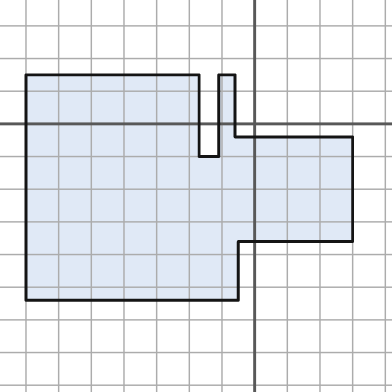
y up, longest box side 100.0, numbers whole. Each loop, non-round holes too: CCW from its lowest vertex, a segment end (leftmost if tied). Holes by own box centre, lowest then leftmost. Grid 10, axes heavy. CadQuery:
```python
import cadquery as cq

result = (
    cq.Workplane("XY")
    .moveTo(-70.0, -54.0)
    .lineTo(-5.0, -54.0)
    .lineTo(-5.0, -36.0)
    .lineTo(30.0, -36.0)
    .lineTo(30.0, -4.0)
    .lineTo(-6.0, -4.0)
    .lineTo(-6.0, 15.0)
    .lineTo(-11.0, 15.0)
    .lineTo(-11.0, -10.0)
    .lineTo(-17.0, -10.0)
    .lineTo(-17.0, 15.0)
    .lineTo(-70.0, 15.0)
    .close()
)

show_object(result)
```